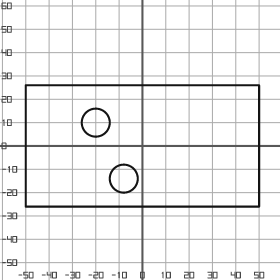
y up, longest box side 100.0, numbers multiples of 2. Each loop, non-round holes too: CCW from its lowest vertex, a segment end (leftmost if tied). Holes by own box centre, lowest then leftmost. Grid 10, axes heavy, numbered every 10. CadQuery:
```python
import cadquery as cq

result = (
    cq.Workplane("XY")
    .moveTo(-50.0, -26.0)
    .lineTo(50.0, -26.0)
    .lineTo(50.0, 26.0)
    .lineTo(-50.0, 26.0)
    .close()
    .moveTo(-8.0, -14.0)
    .circle(6.0)
    .moveTo(-20.0, 10.0)
    .circle(6.0)
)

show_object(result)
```